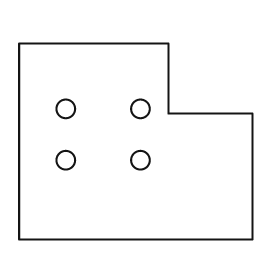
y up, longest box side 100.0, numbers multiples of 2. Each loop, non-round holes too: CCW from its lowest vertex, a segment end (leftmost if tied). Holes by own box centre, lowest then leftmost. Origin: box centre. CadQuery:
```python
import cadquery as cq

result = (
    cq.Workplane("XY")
    .moveTo(-50.0, -42.0)
    .lineTo(50.0, -42.0)
    .lineTo(50.0, 12.0)
    .lineTo(14.0, 12.0)
    .lineTo(14.0, 42.0)
    .lineTo(-50.0, 42.0)
    .close()
    .moveTo(-30.0, -8.0)
    .circle(4.0)
    .moveTo(2.0, -8.0)
    .circle(4.0)
    .moveTo(-30.0, 14.0)
    .circle(4.0)
    .moveTo(2.0, 14.0)
    .circle(4.0)
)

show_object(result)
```